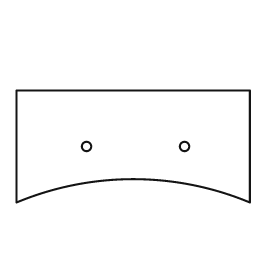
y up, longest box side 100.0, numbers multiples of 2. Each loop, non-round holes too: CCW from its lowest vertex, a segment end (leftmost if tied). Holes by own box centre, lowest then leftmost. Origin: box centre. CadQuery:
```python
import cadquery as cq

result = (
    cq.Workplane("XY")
    .moveTo(-50.0, -24.0)
    .threePointArc((0.0, -14.0), (50.0, -24.0))
    .lineTo(50.0, 24.0)
    .lineTo(-50.0, 24.0)
    .close()
    .moveTo(-20.0, 0.0)
    .circle(2.0)
    .moveTo(22.0, 0.0)
    .circle(2.0)
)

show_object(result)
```